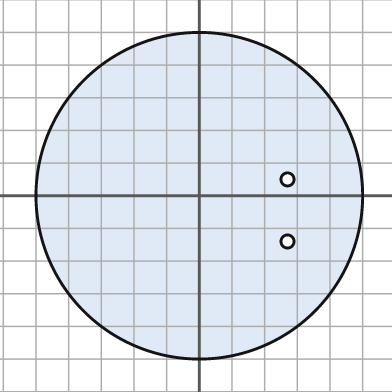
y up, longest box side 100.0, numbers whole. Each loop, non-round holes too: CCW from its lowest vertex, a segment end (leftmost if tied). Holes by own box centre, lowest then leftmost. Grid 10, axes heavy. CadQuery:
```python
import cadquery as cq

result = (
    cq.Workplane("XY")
    .moveTo(0.0, 0.0)
    .circle(50.0)
    .moveTo(27.0, -14.0)
    .circle(2.0)
    .moveTo(27.0, 5.0)
    .circle(2.0)
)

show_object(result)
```